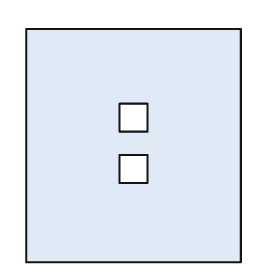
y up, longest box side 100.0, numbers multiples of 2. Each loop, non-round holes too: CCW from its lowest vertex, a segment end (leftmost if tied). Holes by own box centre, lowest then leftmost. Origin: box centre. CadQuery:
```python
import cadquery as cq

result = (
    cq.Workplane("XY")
    .moveTo(-46.0, -50.0)
    .lineTo(46.0, -50.0)
    .lineTo(46.0, 50.0)
    .lineTo(-46.0, 50.0)
    .close()
    .moveTo(-6.0, -16.0)
    .lineTo(6.0, -16.0)
    .lineTo(6.0, -4.0)
    .lineTo(-6.0, -4.0)
    .close()
    .moveTo(-6.0, 6.0)
    .lineTo(6.0, 6.0)
    .lineTo(6.0, 18.0)
    .lineTo(-6.0, 18.0)
    .close()
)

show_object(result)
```